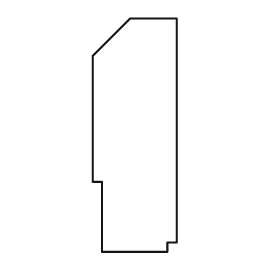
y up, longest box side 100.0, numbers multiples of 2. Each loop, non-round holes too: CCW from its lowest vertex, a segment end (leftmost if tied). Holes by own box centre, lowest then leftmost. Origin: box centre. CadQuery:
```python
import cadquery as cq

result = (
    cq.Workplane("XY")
    .moveTo(-14.0, -50.0)
    .lineTo(14.0, -50.0)
    .lineTo(14.0, -46.0)
    .lineTo(18.0, -46.0)
    .lineTo(18.0, 50.0)
    .lineTo(-2.0, 50.0)
    .lineTo(-18.0, 34.0)
    .lineTo(-18.0, -20.0)
    .lineTo(-14.0, -20.0)
    .close()
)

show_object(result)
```